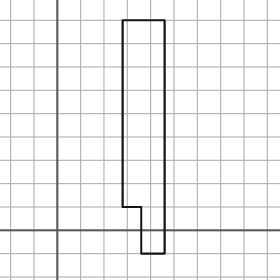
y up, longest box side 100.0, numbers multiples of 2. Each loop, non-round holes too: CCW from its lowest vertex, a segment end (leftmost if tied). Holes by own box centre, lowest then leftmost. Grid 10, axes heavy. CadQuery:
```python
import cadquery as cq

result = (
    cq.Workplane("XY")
    .moveTo(36.0, -10.0)
    .lineTo(46.0, -10.0)
    .lineTo(46.0, 90.0)
    .lineTo(28.0, 90.0)
    .lineTo(28.0, 10.0)
    .lineTo(36.0, 10.0)
    .close()
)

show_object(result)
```